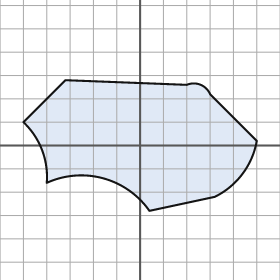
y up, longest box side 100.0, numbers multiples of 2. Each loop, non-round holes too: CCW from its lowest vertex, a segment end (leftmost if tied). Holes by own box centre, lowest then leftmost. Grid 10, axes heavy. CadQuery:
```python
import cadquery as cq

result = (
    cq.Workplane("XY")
    .moveTo(4.0, -28.0)
    .lineTo(32.0, -22.0)
    .threePointArc((44.0, -12.0), (50.0, 2.0))
    .lineTo(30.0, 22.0)
    .threePointArc((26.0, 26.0), (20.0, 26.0))
    .lineTo(-32.0, 28.0)
    .lineTo(-50.0, 10.0)
    .threePointArc((-42.0, -2.0), (-40.0, -16.0))
    .threePointArc((-16.0, -14.0), (4.0, -28.0))
    .close()
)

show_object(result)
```